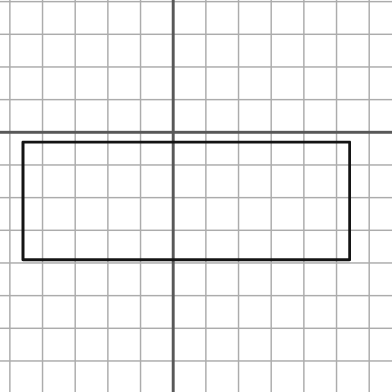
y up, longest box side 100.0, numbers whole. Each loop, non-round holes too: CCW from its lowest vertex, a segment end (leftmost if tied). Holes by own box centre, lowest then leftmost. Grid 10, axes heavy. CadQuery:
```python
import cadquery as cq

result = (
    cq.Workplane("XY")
    .moveTo(-46.0, -39.0)
    .lineTo(54.0, -39.0)
    .lineTo(54.0, -3.0)
    .lineTo(-46.0, -3.0)
    .close()
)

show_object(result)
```